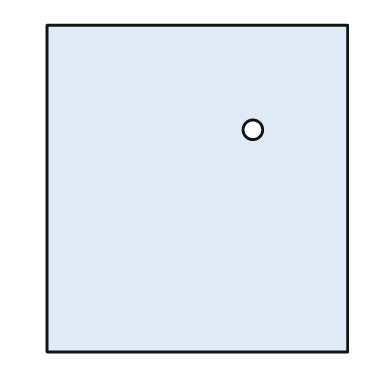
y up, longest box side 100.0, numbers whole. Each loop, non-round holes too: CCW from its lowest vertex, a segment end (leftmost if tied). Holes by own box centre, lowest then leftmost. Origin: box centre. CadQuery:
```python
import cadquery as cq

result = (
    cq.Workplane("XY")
    .moveTo(-46.0, -50.0)
    .lineTo(46.0, -50.0)
    .lineTo(46.0, 50.0)
    .lineTo(-46.0, 50.0)
    .close()
    .moveTo(17.0, 18.0)
    .circle(3.0)
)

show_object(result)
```